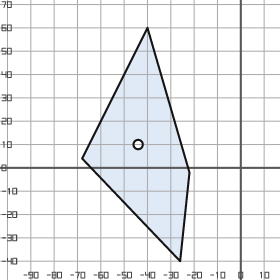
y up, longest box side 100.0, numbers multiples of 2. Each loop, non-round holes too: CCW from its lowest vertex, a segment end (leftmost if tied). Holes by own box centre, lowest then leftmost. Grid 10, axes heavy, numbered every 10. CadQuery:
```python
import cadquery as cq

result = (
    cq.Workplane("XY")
    .moveTo(-26.0, -40.0)
    .lineTo(-22.0, -2.0)
    .lineTo(-40.0, 60.0)
    .lineTo(-68.0, 4.0)
    .close()
    .moveTo(-44.0, 10.0)
    .circle(2.0)
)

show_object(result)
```